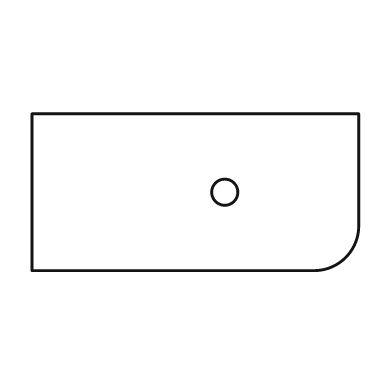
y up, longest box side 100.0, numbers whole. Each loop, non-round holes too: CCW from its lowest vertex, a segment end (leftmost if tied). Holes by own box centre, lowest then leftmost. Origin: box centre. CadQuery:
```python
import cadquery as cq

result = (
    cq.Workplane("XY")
    .moveTo(-50.0, -24.0)
    .lineTo(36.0, -24.0)
    .threePointArc((46.0, -20.0), (50.0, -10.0))
    .lineTo(50.0, 24.0)
    .lineTo(-50.0, 24.0)
    .close()
    .moveTo(9.0, 0.0)
    .circle(4.0)
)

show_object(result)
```